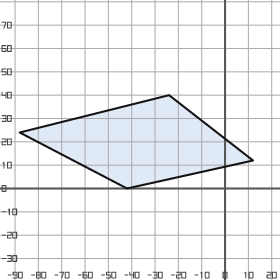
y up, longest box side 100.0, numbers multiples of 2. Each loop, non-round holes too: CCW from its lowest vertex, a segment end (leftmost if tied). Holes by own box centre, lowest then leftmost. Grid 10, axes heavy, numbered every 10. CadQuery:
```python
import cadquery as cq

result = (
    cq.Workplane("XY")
    .moveTo(-42.0, 0.0)
    .lineTo(12.0, 12.0)
    .lineTo(-24.0, 40.0)
    .lineTo(-88.0, 24.0)
    .close()
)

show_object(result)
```